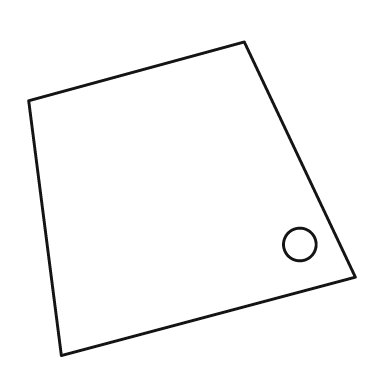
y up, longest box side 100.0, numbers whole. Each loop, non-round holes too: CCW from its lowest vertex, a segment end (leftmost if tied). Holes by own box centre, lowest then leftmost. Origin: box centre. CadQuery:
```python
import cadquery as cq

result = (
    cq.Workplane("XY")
    .moveTo(-40.0, -48.0)
    .lineTo(50.0, -24.0)
    .lineTo(16.0, 48.0)
    .lineTo(-50.0, 30.0)
    .close()
    .moveTo(33.0, -14.0)
    .circle(5.0)
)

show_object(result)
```